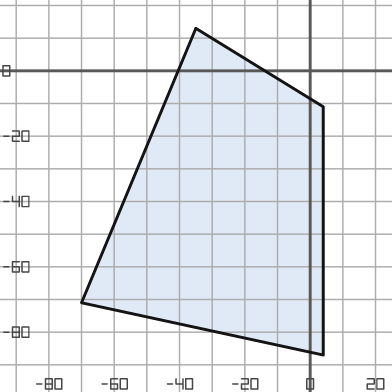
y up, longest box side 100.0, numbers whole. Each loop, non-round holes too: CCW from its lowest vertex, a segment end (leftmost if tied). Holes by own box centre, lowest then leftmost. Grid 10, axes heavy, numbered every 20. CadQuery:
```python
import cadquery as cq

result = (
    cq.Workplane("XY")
    .moveTo(4.0, -87.0)
    .lineTo(4.0, -11.0)
    .lineTo(-35.0, 13.0)
    .lineTo(-70.0, -71.0)
    .close()
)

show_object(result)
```